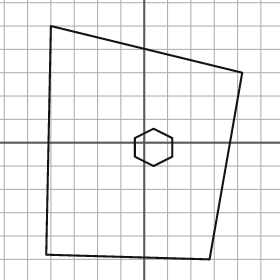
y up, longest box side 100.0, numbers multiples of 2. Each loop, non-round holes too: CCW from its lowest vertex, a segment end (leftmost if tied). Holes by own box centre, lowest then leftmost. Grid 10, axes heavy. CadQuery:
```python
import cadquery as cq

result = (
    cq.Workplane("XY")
    .moveTo(28.0, -50.0)
    .lineTo(42.0, 30.0)
    .lineTo(-40.0, 50.0)
    .lineTo(-42.0, -48.0)
    .close()
    .moveTo(4.0, -10.0)
    .lineTo(12.0, -6.0)
    .lineTo(12.0, 2.0)
    .lineTo(4.0, 6.0)
    .lineTo(-4.0, 2.0)
    .lineTo(-4.0, -6.0)
    .close()
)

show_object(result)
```